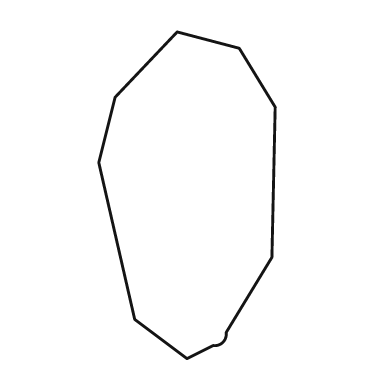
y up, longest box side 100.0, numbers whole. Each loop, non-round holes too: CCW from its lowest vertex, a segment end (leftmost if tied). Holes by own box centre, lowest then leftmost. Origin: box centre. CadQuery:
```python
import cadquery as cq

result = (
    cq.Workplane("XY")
    .moveTo(0.0, -50.0)
    .lineTo(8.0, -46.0)
    .threePointArc((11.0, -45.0), (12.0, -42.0))
    .lineTo(26.0, -19.0)
    .lineTo(27.0, 27.0)
    .lineTo(16.0, 45.0)
    .lineTo(-3.0, 50.0)
    .lineTo(-22.0, 30.0)
    .lineTo(-27.0, 10.0)
    .lineTo(-16.0, -38.0)
    .close()
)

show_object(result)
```